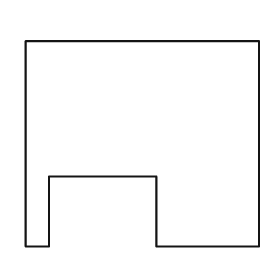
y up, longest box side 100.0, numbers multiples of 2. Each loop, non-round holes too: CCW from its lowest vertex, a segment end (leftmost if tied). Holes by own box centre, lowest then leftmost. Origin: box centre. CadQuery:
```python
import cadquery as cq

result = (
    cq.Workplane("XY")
    .moveTo(-50.0, -44.0)
    .lineTo(-40.0, -44.0)
    .lineTo(-40.0, -14.0)
    .lineTo(6.0, -14.0)
    .lineTo(6.0, -44.0)
    .lineTo(50.0, -44.0)
    .lineTo(50.0, 44.0)
    .lineTo(-50.0, 44.0)
    .close()
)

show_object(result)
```